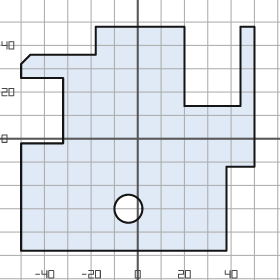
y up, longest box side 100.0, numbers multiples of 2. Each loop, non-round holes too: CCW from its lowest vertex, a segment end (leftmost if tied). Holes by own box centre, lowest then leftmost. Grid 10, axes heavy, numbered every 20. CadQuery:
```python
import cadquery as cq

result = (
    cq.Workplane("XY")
    .moveTo(-50.0, -48.0)
    .lineTo(38.0, -48.0)
    .lineTo(38.0, -12.0)
    .lineTo(50.0, -12.0)
    .lineTo(50.0, 48.0)
    .lineTo(44.0, 48.0)
    .lineTo(44.0, 14.0)
    .lineTo(20.0, 14.0)
    .lineTo(20.0, 48.0)
    .lineTo(-18.0, 48.0)
    .lineTo(-18.0, 36.0)
    .lineTo(-46.0, 36.0)
    .lineTo(-50.0, 32.0)
    .lineTo(-50.0, 26.0)
    .lineTo(-32.0, 26.0)
    .lineTo(-32.0, -2.0)
    .lineTo(-50.0, -2.0)
    .close()
    .moveTo(-4.0, -30.0)
    .circle(6.0)
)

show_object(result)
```